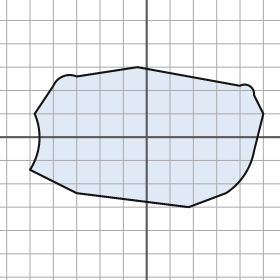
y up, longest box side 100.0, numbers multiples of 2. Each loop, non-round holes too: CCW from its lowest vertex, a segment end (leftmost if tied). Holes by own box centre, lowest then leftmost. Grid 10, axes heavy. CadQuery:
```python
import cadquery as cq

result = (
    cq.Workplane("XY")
    .moveTo(18.0, -30.0)
    .lineTo(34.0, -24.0)
    .threePointArc((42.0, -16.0), (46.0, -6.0))
    .lineTo(50.0, 10.0)
    .lineTo(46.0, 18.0)
    .threePointArc((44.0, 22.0), (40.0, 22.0))
    .lineTo(-4.0, 30.0)
    .lineTo(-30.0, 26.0)
    .threePointArc((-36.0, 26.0), (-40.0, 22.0))
    .lineTo(-48.0, 10.0)
    .threePointArc((-46.0, -2.0), (-50.0, -14.0))
    .lineTo(-30.0, -24.0)
    .close()
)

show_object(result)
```